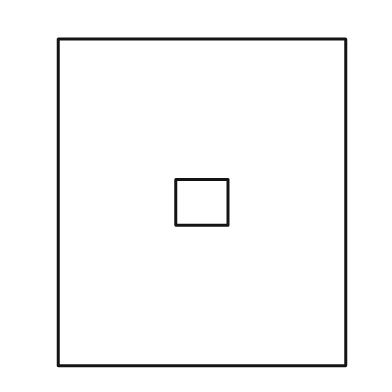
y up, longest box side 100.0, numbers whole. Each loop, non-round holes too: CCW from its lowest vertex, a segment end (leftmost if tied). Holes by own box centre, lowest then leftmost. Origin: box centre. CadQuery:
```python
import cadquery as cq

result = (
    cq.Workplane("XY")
    .moveTo(-44.0, -50.0)
    .lineTo(44.0, -50.0)
    .lineTo(44.0, 50.0)
    .lineTo(-44.0, 50.0)
    .close()
    .moveTo(-8.0, -7.0)
    .lineTo(8.0, -7.0)
    .lineTo(8.0, 7.0)
    .lineTo(-8.0, 7.0)
    .close()
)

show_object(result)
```